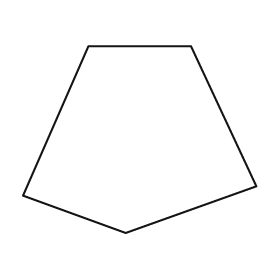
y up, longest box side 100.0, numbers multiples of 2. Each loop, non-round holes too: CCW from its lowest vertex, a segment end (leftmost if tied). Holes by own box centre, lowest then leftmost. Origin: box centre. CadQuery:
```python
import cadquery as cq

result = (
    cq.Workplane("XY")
    .moveTo(-6.0, -40.0)
    .lineTo(50.0, -20.0)
    .lineTo(22.0, 40.0)
    .lineTo(-22.0, 40.0)
    .lineTo(-50.0, -24.0)
    .close()
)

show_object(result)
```